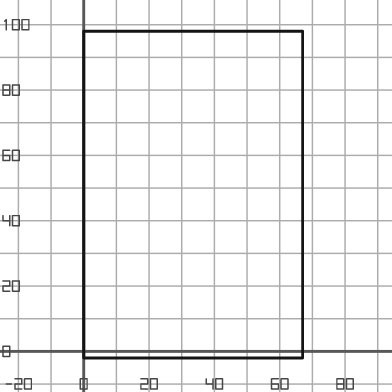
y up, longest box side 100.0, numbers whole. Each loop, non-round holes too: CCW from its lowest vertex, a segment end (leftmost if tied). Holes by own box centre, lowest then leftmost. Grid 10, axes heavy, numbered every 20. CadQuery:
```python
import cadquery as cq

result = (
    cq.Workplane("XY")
    .moveTo(0.0, -2.0)
    .lineTo(67.0, -2.0)
    .lineTo(67.0, 98.0)
    .lineTo(0.0, 98.0)
    .close()
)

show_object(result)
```